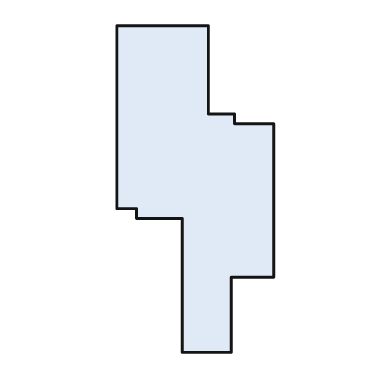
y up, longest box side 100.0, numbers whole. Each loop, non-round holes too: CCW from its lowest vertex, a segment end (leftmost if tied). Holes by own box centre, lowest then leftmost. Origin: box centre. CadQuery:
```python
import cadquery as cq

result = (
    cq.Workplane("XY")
    .moveTo(-4.0, -50.0)
    .lineTo(11.0, -50.0)
    .lineTo(11.0, -27.0)
    .lineTo(24.0, -27.0)
    .lineTo(24.0, 20.0)
    .lineTo(12.0, 20.0)
    .lineTo(12.0, 23.0)
    .lineTo(4.0, 23.0)
    .lineTo(4.0, 50.0)
    .lineTo(-24.0, 50.0)
    .lineTo(-24.0, -6.0)
    .lineTo(-18.0, -6.0)
    .lineTo(-18.0, -9.0)
    .lineTo(-4.0, -9.0)
    .close()
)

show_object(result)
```